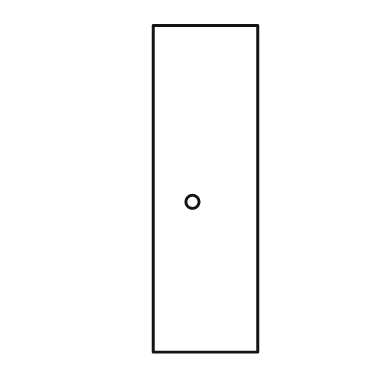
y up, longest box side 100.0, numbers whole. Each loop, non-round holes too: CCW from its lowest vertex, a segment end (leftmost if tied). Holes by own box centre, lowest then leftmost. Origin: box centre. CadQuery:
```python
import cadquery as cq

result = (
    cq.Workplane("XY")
    .moveTo(-16.0, -50.0)
    .lineTo(16.0, -50.0)
    .lineTo(16.0, 50.0)
    .lineTo(-16.0, 50.0)
    .close()
    .moveTo(-4.0, -4.0)
    .circle(2.0)
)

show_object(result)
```